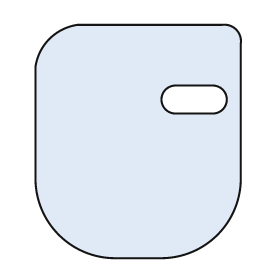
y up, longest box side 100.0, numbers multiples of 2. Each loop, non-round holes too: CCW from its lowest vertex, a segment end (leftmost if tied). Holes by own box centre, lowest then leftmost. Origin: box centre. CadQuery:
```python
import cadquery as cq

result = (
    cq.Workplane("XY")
    .moveTo(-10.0, -50.0)
    .lineTo(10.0, -50.0)
    .threePointArc((34.0, -40.0), (44.0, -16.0))
    .lineTo(44.0, 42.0)
    .threePointArc((42.0, 48.0), (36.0, 50.0))
    .lineTo(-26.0, 50.0)
    .threePointArc((-38.0, 44.0), (-44.0, 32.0))
    .lineTo(-44.0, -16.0)
    .threePointArc((-34.0, -40.0), (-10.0, -50.0))
    .close()
    .moveTo(16.0, 12.0)
    .lineTo(32.0, 12.0)
    .threePointArc((38.0, 18.0), (32.0, 24.0))
    .lineTo(16.0, 24.0)
    .threePointArc((10.0, 18.0), (16.0, 12.0))
    .close()
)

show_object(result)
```